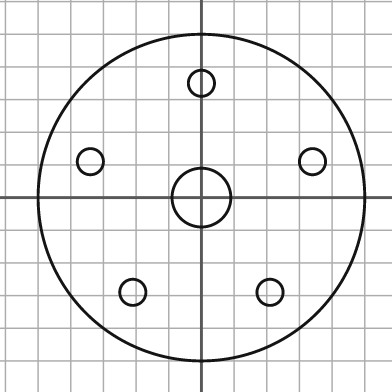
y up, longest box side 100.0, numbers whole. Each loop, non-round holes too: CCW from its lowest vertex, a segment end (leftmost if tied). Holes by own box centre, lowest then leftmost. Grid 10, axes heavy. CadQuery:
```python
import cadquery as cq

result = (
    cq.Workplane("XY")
    .moveTo(0.0, 0.0)
    .circle(50.0)
    .moveTo(-21.0, -29.0)
    .circle(4.0)
    .moveTo(21.0, -29.0)
    .circle(4.0)
    .moveTo(0.0, 0.0)
    .circle(9.0)
    .moveTo(-34.0, 11.0)
    .circle(4.0)
    .moveTo(34.0, 11.0)
    .circle(4.0)
    .moveTo(0.0, 35.0)
    .circle(4.0)
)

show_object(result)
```